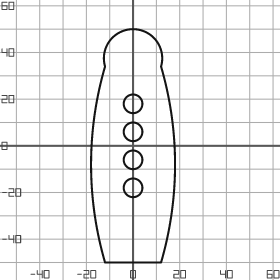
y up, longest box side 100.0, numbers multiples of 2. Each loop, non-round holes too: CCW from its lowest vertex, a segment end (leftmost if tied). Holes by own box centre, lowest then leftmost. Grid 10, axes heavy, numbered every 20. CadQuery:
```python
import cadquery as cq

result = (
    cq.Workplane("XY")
    .moveTo(-12.0, -50.0)
    .lineTo(12.0, -50.0)
    .threePointArc((18.0, -8.0), (12.0, 34.0))
    .threePointArc((0.0, 50.0), (-12.0, 34.0))
    .threePointArc((-18.0, -8.0), (-12.0, -50.0))
    .close()
    .moveTo(0.0, -18.0)
    .circle(4.0)
    .moveTo(0.0, -6.0)
    .circle(4.0)
    .moveTo(0.0, 6.0)
    .circle(4.0)
    .moveTo(0.0, 18.0)
    .circle(4.0)
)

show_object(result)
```